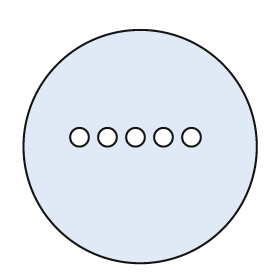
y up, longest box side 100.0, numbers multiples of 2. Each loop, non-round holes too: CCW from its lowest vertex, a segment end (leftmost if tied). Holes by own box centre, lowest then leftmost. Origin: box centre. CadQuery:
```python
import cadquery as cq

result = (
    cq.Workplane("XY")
    .moveTo(0.0, 0.0)
    .circle(50.0)
    .moveTo(-26.0, 4.0)
    .circle(4.0)
    .moveTo(-14.0, 4.0)
    .circle(4.0)
    .moveTo(-2.0, 4.0)
    .circle(4.0)
    .moveTo(10.0, 4.0)
    .circle(4.0)
    .moveTo(22.0, 4.0)
    .circle(4.0)
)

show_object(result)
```